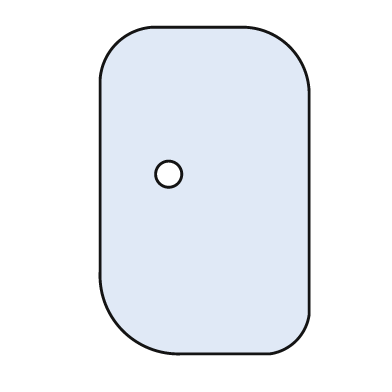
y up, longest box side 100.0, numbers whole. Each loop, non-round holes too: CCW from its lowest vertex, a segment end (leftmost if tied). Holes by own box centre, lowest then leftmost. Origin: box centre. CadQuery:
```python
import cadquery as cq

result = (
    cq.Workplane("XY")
    .moveTo(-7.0, -50.0)
    .lineTo(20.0, -50.0)
    .threePointArc((28.0, -46.0), (32.0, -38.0))
    .lineTo(32.0, 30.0)
    .threePointArc((26.0, 44.0), (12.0, 50.0))
    .lineTo(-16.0, 50.0)
    .threePointArc((-27.0, 45.0), (-32.0, 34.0))
    .lineTo(-32.0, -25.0)
    .threePointArc((-25.0, -43.0), (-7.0, -50.0))
    .close()
    .moveTo(-11.0, 5.0)
    .circle(4.0)
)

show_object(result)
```